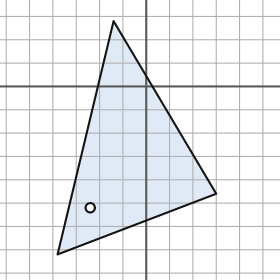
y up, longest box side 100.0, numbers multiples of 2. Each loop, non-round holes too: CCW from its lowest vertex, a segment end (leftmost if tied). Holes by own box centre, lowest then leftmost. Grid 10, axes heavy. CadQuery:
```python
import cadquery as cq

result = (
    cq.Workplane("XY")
    .moveTo(-38.0, -72.0)
    .lineTo(30.0, -46.0)
    .lineTo(-14.0, 28.0)
    .close()
    .moveTo(-24.0, -52.0)
    .circle(2.0)
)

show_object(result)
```